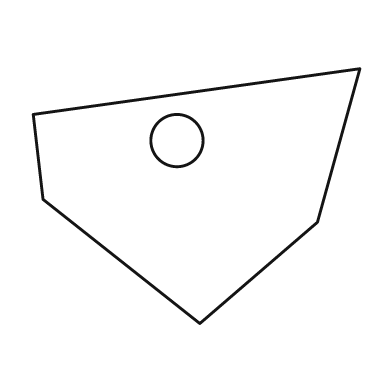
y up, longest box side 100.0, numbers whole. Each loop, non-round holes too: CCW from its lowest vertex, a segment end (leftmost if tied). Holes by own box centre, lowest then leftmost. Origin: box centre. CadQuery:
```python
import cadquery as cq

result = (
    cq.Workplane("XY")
    .moveTo(1.0, -39.0)
    .lineTo(37.0, -8.0)
    .lineTo(50.0, 39.0)
    .lineTo(-50.0, 25.0)
    .lineTo(-47.0, -1.0)
    .close()
    .moveTo(-6.0, 17.0)
    .circle(8.0)
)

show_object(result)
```